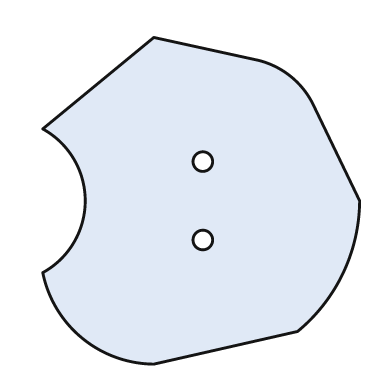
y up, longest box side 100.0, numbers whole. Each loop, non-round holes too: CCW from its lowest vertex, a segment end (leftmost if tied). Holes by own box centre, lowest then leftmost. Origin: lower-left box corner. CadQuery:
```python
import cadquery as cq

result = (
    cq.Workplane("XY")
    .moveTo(34.0, 0.0)
    .lineTo(78.0, 10.0)
    .threePointArc((92.0, 28.0), (97.0, 50.0))
    .lineTo(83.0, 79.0)
    .threePointArc((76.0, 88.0), (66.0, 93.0))
    .lineTo(34.0, 100.0)
    .lineTo(0.0, 72.0)
    .threePointArc((13.0, 50.0), (0.0, 28.0))
    .threePointArc((12.0, 8.0), (34.0, 0.0))
    .close()
    .moveTo(49.0, 38.0)
    .circle(3.0)
    .moveTo(49.0, 62.0)
    .circle(3.0)
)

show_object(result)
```